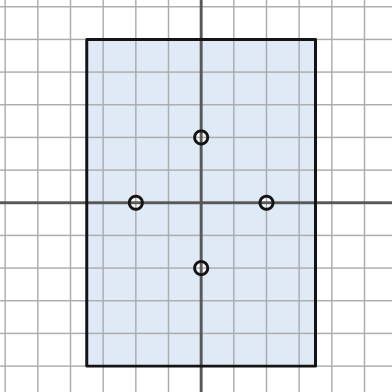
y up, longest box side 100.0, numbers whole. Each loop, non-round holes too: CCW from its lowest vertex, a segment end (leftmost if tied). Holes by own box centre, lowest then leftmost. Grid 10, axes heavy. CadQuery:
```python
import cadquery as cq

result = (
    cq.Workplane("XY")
    .moveTo(-35.0, -50.0)
    .lineTo(35.0, -50.0)
    .lineTo(35.0, 50.0)
    .lineTo(-35.0, 50.0)
    .close()
    .moveTo(0.0, -20.0)
    .circle(2.0)
    .moveTo(-20.0, 0.0)
    .circle(2.0)
    .moveTo(20.0, 0.0)
    .circle(2.0)
    .moveTo(0.0, 20.0)
    .circle(2.0)
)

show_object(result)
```